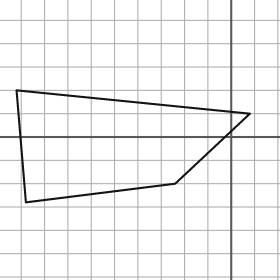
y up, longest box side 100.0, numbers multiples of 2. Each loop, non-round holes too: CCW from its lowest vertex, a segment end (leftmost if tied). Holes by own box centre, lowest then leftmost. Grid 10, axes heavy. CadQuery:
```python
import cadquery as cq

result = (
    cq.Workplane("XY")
    .moveTo(-88.0, -28.0)
    .lineTo(-24.0, -20.0)
    .lineTo(8.0, 10.0)
    .lineTo(-92.0, 20.0)
    .close()
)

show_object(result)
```